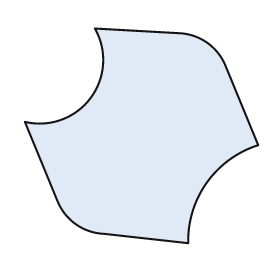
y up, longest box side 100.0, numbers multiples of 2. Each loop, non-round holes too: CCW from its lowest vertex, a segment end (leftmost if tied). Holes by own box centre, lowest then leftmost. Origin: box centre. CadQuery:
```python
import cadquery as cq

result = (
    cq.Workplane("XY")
    .moveTo(20.0, -46.0)
    .threePointArc((28.0, -20.0), (50.0, -4.0))
    .lineTo(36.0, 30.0)
    .threePointArc((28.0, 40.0), (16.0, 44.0))
    .lineTo(-20.0, 46.0)
    .threePointArc((-22.0, 16.0), (-50.0, 6.0))
    .lineTo(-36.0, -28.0)
    .threePointArc((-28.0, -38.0), (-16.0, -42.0))
    .close()
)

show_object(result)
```